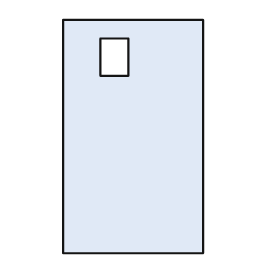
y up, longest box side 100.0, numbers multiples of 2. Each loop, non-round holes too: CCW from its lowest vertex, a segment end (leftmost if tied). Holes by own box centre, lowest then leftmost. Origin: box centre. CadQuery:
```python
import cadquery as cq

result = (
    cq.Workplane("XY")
    .moveTo(-30.0, -50.0)
    .lineTo(30.0, -50.0)
    .lineTo(30.0, 50.0)
    .lineTo(-30.0, 50.0)
    .close()
    .moveTo(-14.0, 26.0)
    .lineTo(-2.0, 26.0)
    .lineTo(-2.0, 42.0)
    .lineTo(-14.0, 42.0)
    .close()
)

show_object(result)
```